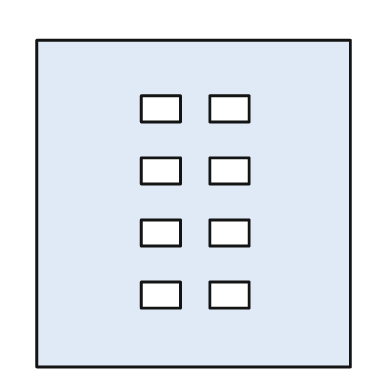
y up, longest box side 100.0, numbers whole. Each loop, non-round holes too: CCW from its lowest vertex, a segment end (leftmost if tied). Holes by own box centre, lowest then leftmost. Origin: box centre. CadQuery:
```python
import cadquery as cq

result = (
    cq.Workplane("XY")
    .moveTo(-48.0, -50.0)
    .lineTo(48.0, -50.0)
    .lineTo(48.0, 50.0)
    .lineTo(-48.0, 50.0)
    .close()
    .moveTo(-16.0, -32.0)
    .lineTo(-4.0, -32.0)
    .lineTo(-4.0, -24.0)
    .lineTo(-16.0, -24.0)
    .close()
    .moveTo(5.0, -32.0)
    .lineTo(17.0, -32.0)
    .lineTo(17.0, -24.0)
    .lineTo(5.0, -24.0)
    .close()
    .moveTo(-16.0, -13.0)
    .lineTo(-4.0, -13.0)
    .lineTo(-4.0, -5.0)
    .lineTo(-16.0, -5.0)
    .close()
    .moveTo(5.0, -13.0)
    .lineTo(17.0, -13.0)
    .lineTo(17.0, -5.0)
    .lineTo(5.0, -5.0)
    .close()
    .moveTo(-16.0, 6.0)
    .lineTo(-4.0, 6.0)
    .lineTo(-4.0, 14.0)
    .lineTo(-16.0, 14.0)
    .close()
    .moveTo(5.0, 6.0)
    .lineTo(17.0, 6.0)
    .lineTo(17.0, 14.0)
    .lineTo(5.0, 14.0)
    .close()
    .moveTo(-16.0, 25.0)
    .lineTo(-4.0, 25.0)
    .lineTo(-4.0, 33.0)
    .lineTo(-16.0, 33.0)
    .close()
    .moveTo(5.0, 25.0)
    .lineTo(17.0, 25.0)
    .lineTo(17.0, 33.0)
    .lineTo(5.0, 33.0)
    .close()
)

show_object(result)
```